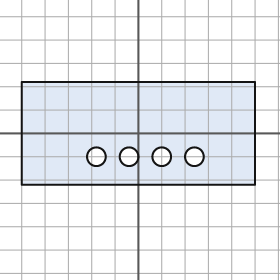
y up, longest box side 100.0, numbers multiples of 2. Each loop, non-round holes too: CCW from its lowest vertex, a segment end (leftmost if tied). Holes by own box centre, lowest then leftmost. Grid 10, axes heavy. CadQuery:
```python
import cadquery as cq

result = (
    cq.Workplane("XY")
    .moveTo(-50.0, -22.0)
    .lineTo(50.0, -22.0)
    .lineTo(50.0, 22.0)
    .lineTo(-50.0, 22.0)
    .close()
    .moveTo(-18.0, -10.0)
    .circle(4.0)
    .moveTo(-4.0, -10.0)
    .circle(4.0)
    .moveTo(10.0, -10.0)
    .circle(4.0)
    .moveTo(24.0, -10.0)
    .circle(4.0)
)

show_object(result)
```